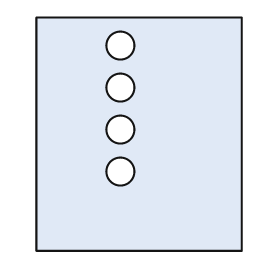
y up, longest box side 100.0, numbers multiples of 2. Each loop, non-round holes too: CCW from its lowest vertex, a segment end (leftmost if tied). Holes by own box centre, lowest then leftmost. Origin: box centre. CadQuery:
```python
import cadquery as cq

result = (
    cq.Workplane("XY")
    .moveTo(-44.0, -50.0)
    .lineTo(44.0, -50.0)
    .lineTo(44.0, 50.0)
    .lineTo(-44.0, 50.0)
    .close()
    .moveTo(-8.0, -16.0)
    .circle(6.0)
    .moveTo(-8.0, 2.0)
    .circle(6.0)
    .moveTo(-8.0, 20.0)
    .circle(6.0)
    .moveTo(-8.0, 38.0)
    .circle(6.0)
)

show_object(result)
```